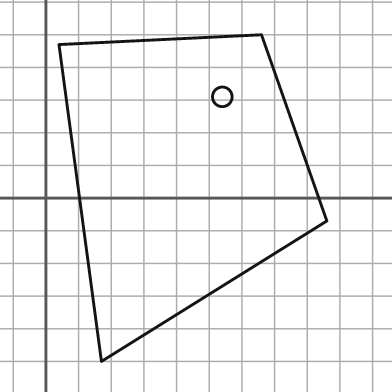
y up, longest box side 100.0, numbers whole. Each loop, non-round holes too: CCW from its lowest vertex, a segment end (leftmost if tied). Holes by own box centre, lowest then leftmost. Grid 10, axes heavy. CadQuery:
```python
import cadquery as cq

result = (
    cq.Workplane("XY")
    .moveTo(17.0, -50.0)
    .lineTo(86.0, -7.0)
    .lineTo(66.0, 50.0)
    .lineTo(4.0, 47.0)
    .close()
    .moveTo(54.0, 31.0)
    .circle(3.0)
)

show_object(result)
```